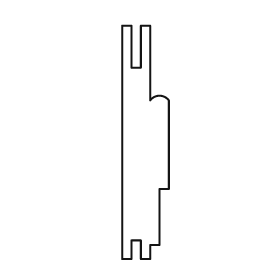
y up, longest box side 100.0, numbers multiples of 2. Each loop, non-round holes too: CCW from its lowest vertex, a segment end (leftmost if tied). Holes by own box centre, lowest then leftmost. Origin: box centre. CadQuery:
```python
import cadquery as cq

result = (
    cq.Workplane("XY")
    .moveTo(-10.0, -50.0)
    .lineTo(-6.0, -50.0)
    .lineTo(-6.0, -42.0)
    .lineTo(-2.0, -42.0)
    .lineTo(-2.0, -50.0)
    .lineTo(2.0, -50.0)
    .lineTo(2.0, -44.0)
    .lineTo(6.0, -44.0)
    .lineTo(6.0, -20.0)
    .lineTo(10.0, -20.0)
    .lineTo(10.0, 18.0)
    .threePointArc((6.0, 20.0), (2.0, 18.0))
    .lineTo(2.0, 50.0)
    .lineTo(-2.0, 50.0)
    .lineTo(-2.0, 32.0)
    .lineTo(-6.0, 32.0)
    .lineTo(-6.0, 50.0)
    .lineTo(-10.0, 50.0)
    .close()
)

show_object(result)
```